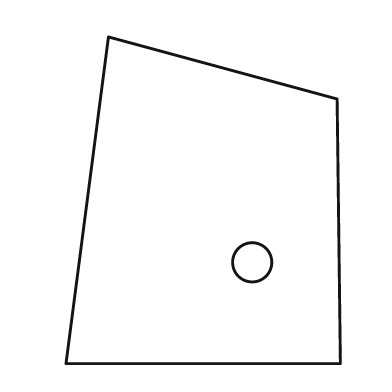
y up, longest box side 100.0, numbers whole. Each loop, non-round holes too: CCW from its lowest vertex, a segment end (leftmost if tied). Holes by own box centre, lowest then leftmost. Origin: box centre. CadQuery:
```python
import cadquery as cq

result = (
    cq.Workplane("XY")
    .moveTo(-42.0, -50.0)
    .lineTo(42.0, -50.0)
    .lineTo(41.0, 31.0)
    .lineTo(-29.0, 50.0)
    .close()
    .moveTo(15.0, -19.0)
    .circle(6.0)
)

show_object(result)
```